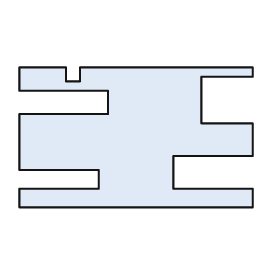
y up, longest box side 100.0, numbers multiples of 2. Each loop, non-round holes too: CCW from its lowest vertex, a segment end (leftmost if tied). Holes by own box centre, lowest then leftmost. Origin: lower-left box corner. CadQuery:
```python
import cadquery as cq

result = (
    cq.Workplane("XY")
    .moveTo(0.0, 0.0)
    .lineTo(100.0, 0.0)
    .lineTo(100.0, 8.0)
    .lineTo(66.0, 8.0)
    .lineTo(66.0, 22.0)
    .lineTo(100.0, 22.0)
    .lineTo(100.0, 36.0)
    .lineTo(78.0, 36.0)
    .lineTo(78.0, 56.0)
    .lineTo(100.0, 56.0)
    .lineTo(100.0, 60.0)
    .lineTo(26.0, 60.0)
    .lineTo(26.0, 54.0)
    .lineTo(20.0, 54.0)
    .lineTo(20.0, 60.0)
    .lineTo(0.0, 60.0)
    .lineTo(0.0, 50.0)
    .lineTo(38.0, 50.0)
    .lineTo(38.0, 40.0)
    .lineTo(0.0, 40.0)
    .lineTo(0.0, 16.0)
    .lineTo(34.0, 16.0)
    .lineTo(34.0, 8.0)
    .lineTo(0.0, 8.0)
    .close()
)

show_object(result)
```